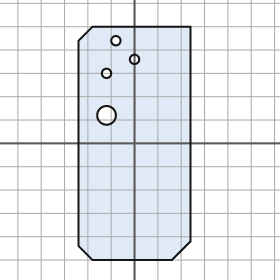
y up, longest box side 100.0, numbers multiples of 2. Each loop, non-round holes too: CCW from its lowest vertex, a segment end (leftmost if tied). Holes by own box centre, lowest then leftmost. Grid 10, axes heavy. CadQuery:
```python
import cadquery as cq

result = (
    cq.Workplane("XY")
    .moveTo(-18.0, -50.0)
    .lineTo(16.0, -50.0)
    .lineTo(24.0, -42.0)
    .lineTo(24.0, 50.0)
    .lineTo(-18.0, 50.0)
    .lineTo(-24.0, 44.0)
    .lineTo(-24.0, -44.0)
    .close()
    .moveTo(-12.0, 12.0)
    .circle(4.0)
    .moveTo(-12.0, 30.0)
    .circle(2.0)
    .moveTo(0.0, 36.0)
    .circle(2.0)
    .moveTo(-8.0, 44.0)
    .circle(2.0)
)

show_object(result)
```